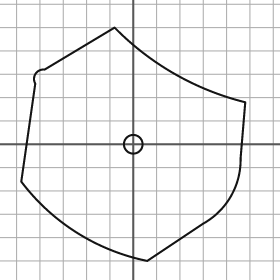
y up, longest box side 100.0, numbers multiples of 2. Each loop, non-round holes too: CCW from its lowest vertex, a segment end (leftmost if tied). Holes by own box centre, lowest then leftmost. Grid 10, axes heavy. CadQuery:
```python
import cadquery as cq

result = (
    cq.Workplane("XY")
    .moveTo(6.0, -50.0)
    .lineTo(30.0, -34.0)
    .threePointArc((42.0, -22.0), (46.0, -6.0))
    .lineTo(48.0, 18.0)
    .threePointArc((18.0, 30.0), (-8.0, 50.0))
    .lineTo(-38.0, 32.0)
    .threePointArc((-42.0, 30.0), (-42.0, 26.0))
    .lineTo(-48.0, -16.0)
    .threePointArc((-24.0, -38.0), (6.0, -50.0))
    .close()
    .moveTo(0.0, 0.0)
    .circle(4.0)
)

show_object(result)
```